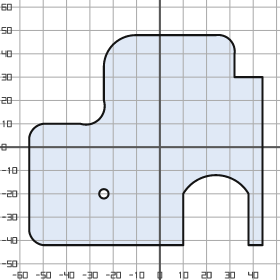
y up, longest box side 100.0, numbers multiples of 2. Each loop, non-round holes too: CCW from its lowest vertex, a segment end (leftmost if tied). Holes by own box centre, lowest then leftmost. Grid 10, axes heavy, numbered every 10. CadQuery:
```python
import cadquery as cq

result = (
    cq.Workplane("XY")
    .moveTo(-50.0, -42.0)
    .lineTo(10.0, -42.0)
    .lineTo(10.0, -20.0)
    .threePointArc((24.0, -12.0), (38.0, -20.0))
    .lineTo(38.0, -42.0)
    .lineTo(44.0, -42.0)
    .lineTo(44.0, 30.0)
    .lineTo(32.0, 30.0)
    .lineTo(32.0, 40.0)
    .threePointArc((30.0, 46.0), (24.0, 48.0))
    .lineTo(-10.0, 48.0)
    .threePointArc((-20.0, 44.0), (-24.0, 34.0))
    .lineTo(-24.0, 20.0)
    .threePointArc((-26.0, 12.0), (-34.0, 10.0))
    .lineTo(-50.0, 10.0)
    .threePointArc((-54.0, 8.0), (-56.0, 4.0))
    .lineTo(-56.0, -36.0)
    .threePointArc((-54.0, -40.0), (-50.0, -42.0))
    .close()
    .moveTo(-24.0, -20.0)
    .circle(2.0)
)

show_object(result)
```